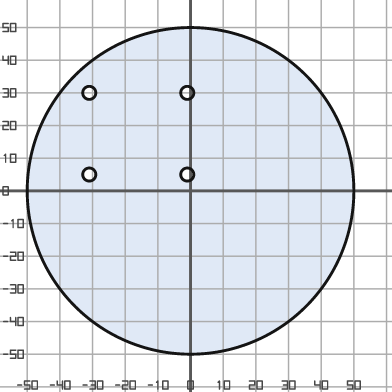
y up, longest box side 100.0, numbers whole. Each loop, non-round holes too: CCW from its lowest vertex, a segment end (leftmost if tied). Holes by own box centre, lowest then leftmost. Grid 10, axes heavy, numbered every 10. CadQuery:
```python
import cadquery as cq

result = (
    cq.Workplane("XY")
    .moveTo(0.0, 0.0)
    .circle(50.0)
    .moveTo(-31.0, 5.0)
    .circle(2.0)
    .moveTo(-1.0, 5.0)
    .circle(2.0)
    .moveTo(-31.0, 30.0)
    .circle(2.0)
    .moveTo(-1.0, 30.0)
    .circle(2.0)
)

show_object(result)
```